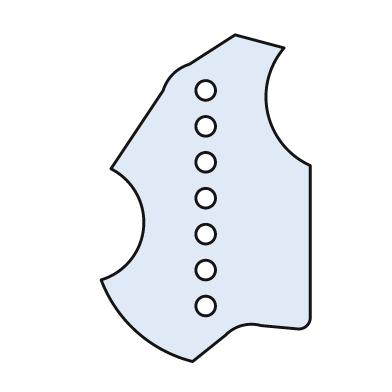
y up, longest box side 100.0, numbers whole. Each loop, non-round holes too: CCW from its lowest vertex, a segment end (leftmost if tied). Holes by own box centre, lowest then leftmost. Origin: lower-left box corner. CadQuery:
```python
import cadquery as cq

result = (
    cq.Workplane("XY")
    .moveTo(28.0, 0.0)
    .lineTo(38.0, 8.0)
    .threePointArc((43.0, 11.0), (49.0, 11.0))
    .lineTo(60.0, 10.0)
    .threePointArc((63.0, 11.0), (64.0, 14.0))
    .lineTo(64.0, 60.0)
    .threePointArc((51.0, 76.0), (56.0, 96.0))
    .lineTo(41.0, 100.0)
    .lineTo(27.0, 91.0)
    .threePointArc((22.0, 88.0), (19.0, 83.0))
    .lineTo(3.0, 59.0)
    .threePointArc((13.0, 41.0), (0.0, 25.0))
    .threePointArc((11.0, 9.0), (28.0, 0.0))
    .close()
    .moveTo(32.0, 17.0)
    .circle(3.0)
    .moveTo(32.0, 28.0)
    .circle(3.0)
    .moveTo(32.0, 39.0)
    .circle(3.0)
    .moveTo(32.0, 50.0)
    .circle(3.0)
    .moveTo(32.0, 61.0)
    .circle(3.0)
    .moveTo(32.0, 72.0)
    .circle(3.0)
    .moveTo(32.0, 83.0)
    .circle(3.0)
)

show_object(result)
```